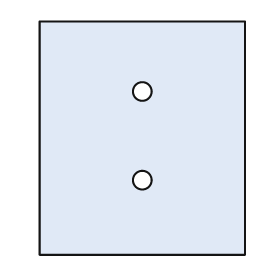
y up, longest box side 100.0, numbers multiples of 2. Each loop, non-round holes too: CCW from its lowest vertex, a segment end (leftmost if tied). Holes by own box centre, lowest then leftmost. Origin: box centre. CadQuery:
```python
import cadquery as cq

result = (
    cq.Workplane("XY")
    .moveTo(-44.0, -50.0)
    .lineTo(44.0, -50.0)
    .lineTo(44.0, 50.0)
    .lineTo(-44.0, 50.0)
    .close()
    .moveTo(0.0, -18.0)
    .circle(4.0)
    .moveTo(0.0, 20.0)
    .circle(4.0)
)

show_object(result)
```